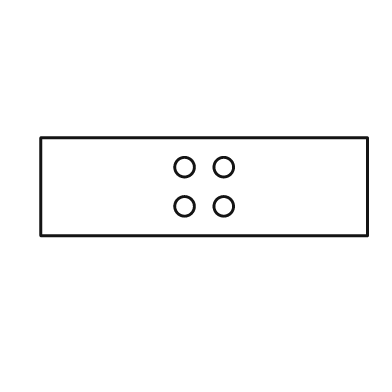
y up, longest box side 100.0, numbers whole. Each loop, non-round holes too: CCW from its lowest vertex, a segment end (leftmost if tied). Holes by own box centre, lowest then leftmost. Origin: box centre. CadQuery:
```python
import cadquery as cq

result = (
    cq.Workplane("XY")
    .moveTo(-50.0, -15.0)
    .lineTo(50.0, -15.0)
    .lineTo(50.0, 15.0)
    .lineTo(-50.0, 15.0)
    .close()
    .moveTo(-6.0, -6.0)
    .circle(3.0)
    .moveTo(6.0, -6.0)
    .circle(3.0)
    .moveTo(-6.0, 6.0)
    .circle(3.0)
    .moveTo(6.0, 6.0)
    .circle(3.0)
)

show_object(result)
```